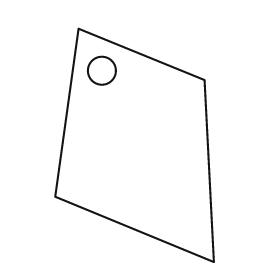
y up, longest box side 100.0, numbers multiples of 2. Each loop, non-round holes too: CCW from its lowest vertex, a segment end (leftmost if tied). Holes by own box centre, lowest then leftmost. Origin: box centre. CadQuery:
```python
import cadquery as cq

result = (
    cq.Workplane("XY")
    .moveTo(34.0, -50.0)
    .lineTo(30.0, 28.0)
    .lineTo(-24.0, 50.0)
    .lineTo(-34.0, -22.0)
    .close()
    .moveTo(-14.0, 32.0)
    .circle(6.0)
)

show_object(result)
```